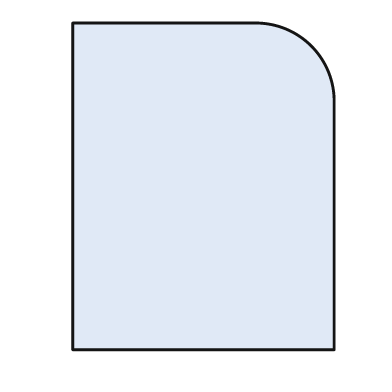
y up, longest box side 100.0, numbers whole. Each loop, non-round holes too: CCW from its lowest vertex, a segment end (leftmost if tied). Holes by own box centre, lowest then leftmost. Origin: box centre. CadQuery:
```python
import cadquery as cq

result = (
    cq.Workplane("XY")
    .moveTo(-40.0, -50.0)
    .lineTo(40.0, -50.0)
    .lineTo(40.0, 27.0)
    .threePointArc((33.0, 43.0), (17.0, 50.0))
    .lineTo(-40.0, 50.0)
    .close()
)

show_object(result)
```